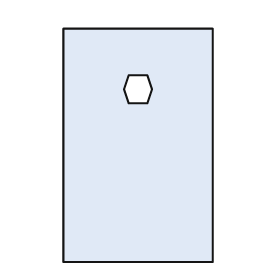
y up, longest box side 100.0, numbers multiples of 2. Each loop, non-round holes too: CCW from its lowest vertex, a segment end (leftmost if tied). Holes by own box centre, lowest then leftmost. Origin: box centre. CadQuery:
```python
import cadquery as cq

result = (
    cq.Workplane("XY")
    .moveTo(-32.0, -50.0)
    .lineTo(32.0, -50.0)
    .lineTo(32.0, 50.0)
    .lineTo(-32.0, 50.0)
    .close()
    .moveTo(-4.0, 18.0)
    .lineTo(4.0, 18.0)
    .lineTo(6.0, 24.0)
    .lineTo(4.0, 30.0)
    .lineTo(-4.0, 30.0)
    .lineTo(-6.0, 24.0)
    .close()
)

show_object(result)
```